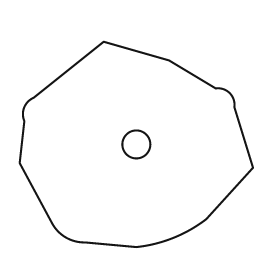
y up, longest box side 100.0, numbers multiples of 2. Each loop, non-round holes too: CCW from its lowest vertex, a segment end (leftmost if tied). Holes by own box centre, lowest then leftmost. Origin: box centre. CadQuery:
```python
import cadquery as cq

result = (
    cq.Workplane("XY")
    .moveTo(0.0, -44.0)
    .threePointArc((16.0, -40.0), (30.0, -32.0))
    .lineTo(50.0, -10.0)
    .lineTo(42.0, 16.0)
    .threePointArc((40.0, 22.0), (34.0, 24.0))
    .lineTo(14.0, 36.0)
    .lineTo(-14.0, 44.0)
    .lineTo(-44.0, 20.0)
    .threePointArc((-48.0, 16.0), (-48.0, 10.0))
    .lineTo(-50.0, -8.0)
    .lineTo(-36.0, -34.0)
    .threePointArc((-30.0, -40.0), (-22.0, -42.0))
    .close()
    .moveTo(0.0, 0.0)
    .circle(6.0)
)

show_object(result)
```